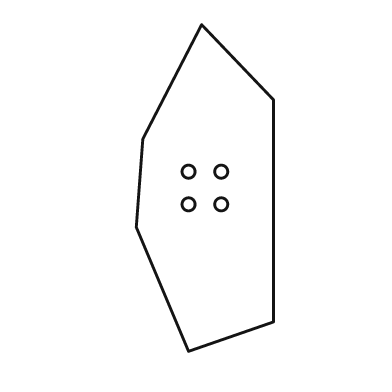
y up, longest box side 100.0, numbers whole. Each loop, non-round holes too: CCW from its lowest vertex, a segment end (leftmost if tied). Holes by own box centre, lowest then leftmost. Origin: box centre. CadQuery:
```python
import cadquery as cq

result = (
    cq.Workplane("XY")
    .moveTo(-5.0, -50.0)
    .lineTo(21.0, -41.0)
    .lineTo(21.0, 27.0)
    .lineTo(-1.0, 50.0)
    .lineTo(-19.0, 15.0)
    .lineTo(-21.0, -12.0)
    .close()
    .moveTo(-5.0, -5.0)
    .circle(2.0)
    .moveTo(5.0, -5.0)
    .circle(2.0)
    .moveTo(-5.0, 5.0)
    .circle(2.0)
    .moveTo(5.0, 5.0)
    .circle(2.0)
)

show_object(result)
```